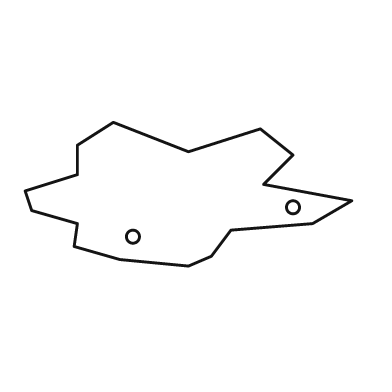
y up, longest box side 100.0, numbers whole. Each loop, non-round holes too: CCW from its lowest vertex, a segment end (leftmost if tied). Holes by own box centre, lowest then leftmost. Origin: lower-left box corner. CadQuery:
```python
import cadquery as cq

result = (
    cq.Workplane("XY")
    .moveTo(50.0, 0.0)
    .lineTo(57.0, 3.0)
    .lineTo(63.0, 11.0)
    .lineTo(88.0, 13.0)
    .lineTo(100.0, 20.0)
    .lineTo(73.0, 25.0)
    .lineTo(82.0, 34.0)
    .lineTo(72.0, 42.0)
    .lineTo(50.0, 35.0)
    .lineTo(27.0, 44.0)
    .lineTo(16.0, 37.0)
    .lineTo(16.0, 28.0)
    .lineTo(0.0, 23.0)
    .lineTo(2.0, 17.0)
    .lineTo(16.0, 13.0)
    .lineTo(15.0, 6.0)
    .lineTo(29.0, 2.0)
    .close()
    .moveTo(33.0, 9.0)
    .circle(2.0)
    .moveTo(82.0, 18.0)
    .circle(2.0)
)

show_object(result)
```